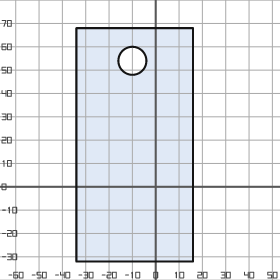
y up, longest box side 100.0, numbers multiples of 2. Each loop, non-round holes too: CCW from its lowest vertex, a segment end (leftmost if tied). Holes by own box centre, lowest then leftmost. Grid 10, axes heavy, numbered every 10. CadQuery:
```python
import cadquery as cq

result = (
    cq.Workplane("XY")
    .moveTo(-34.0, -32.0)
    .lineTo(16.0, -32.0)
    .lineTo(16.0, 68.0)
    .lineTo(-34.0, 68.0)
    .close()
    .moveTo(-10.0, 54.0)
    .circle(6.0)
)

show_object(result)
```